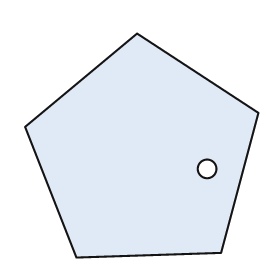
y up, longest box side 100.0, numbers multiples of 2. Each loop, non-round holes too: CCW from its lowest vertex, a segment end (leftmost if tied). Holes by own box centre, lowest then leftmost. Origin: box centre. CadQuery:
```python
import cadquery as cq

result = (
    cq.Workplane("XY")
    .moveTo(-28.0, -48.0)
    .lineTo(34.0, -46.0)
    .lineTo(50.0, 14.0)
    .lineTo(-2.0, 48.0)
    .lineTo(-50.0, 8.0)
    .close()
    .moveTo(28.0, -10.0)
    .circle(4.0)
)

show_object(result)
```